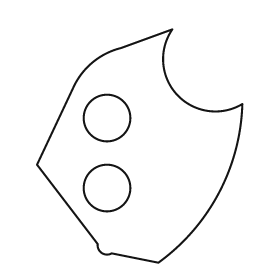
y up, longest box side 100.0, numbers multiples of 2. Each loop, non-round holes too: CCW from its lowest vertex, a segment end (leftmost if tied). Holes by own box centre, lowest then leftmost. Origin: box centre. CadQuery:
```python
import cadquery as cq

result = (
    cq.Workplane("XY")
    .moveTo(8.0, -50.0)
    .threePointArc((34.0, -20.0), (44.0, 18.0))
    .threePointArc((16.0, 22.0), (14.0, 50.0))
    .lineTo(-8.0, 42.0)
    .threePointArc((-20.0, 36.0), (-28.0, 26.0))
    .lineTo(-44.0, -8.0)
    .lineTo(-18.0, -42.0)
    .threePointArc((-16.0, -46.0), (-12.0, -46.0))
    .close()
    .moveTo(-14.0, -18.0)
    .circle(10.0)
    .moveTo(-14.0, 12.0)
    .circle(10.0)
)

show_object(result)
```